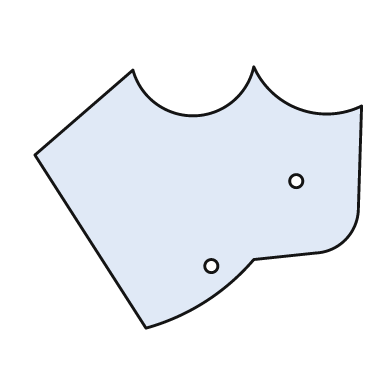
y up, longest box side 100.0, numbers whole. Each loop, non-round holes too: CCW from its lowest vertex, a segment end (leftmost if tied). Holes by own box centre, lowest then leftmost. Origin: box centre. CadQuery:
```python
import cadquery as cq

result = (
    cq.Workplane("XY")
    .moveTo(-16.0, -40.0)
    .threePointArc((2.0, -32.0), (17.0, -19.0))
    .lineTo(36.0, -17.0)
    .threePointArc((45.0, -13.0), (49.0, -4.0))
    .lineTo(50.0, 28.0)
    .threePointArc((31.0, 27.0), (17.0, 40.0))
    .threePointArc((-1.0, 25.0), (-20.0, 39.0))
    .lineTo(-50.0, 13.0)
    .close()
    .moveTo(4.0, -21.0)
    .circle(2.0)
    .moveTo(30.0, 5.0)
    .circle(2.0)
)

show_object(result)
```